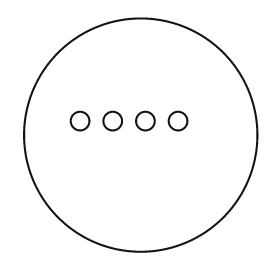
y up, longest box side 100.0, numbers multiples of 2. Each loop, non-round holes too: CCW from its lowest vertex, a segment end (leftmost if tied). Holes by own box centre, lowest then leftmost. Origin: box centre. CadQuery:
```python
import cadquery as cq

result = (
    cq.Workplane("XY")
    .moveTo(0.0, 0.0)
    .circle(50.0)
    .moveTo(-26.0, 6.0)
    .circle(4.0)
    .moveTo(-12.0, 6.0)
    .circle(4.0)
    .moveTo(2.0, 6.0)
    .circle(4.0)
    .moveTo(16.0, 6.0)
    .circle(4.0)
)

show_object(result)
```